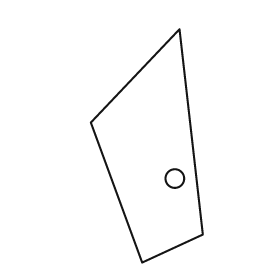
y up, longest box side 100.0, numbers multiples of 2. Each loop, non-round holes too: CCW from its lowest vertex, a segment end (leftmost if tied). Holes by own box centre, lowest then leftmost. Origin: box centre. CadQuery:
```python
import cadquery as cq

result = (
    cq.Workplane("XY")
    .moveTo(-2.0, -50.0)
    .lineTo(24.0, -38.0)
    .lineTo(14.0, 50.0)
    .lineTo(-24.0, 10.0)
    .close()
    .moveTo(12.0, -14.0)
    .circle(4.0)
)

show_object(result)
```